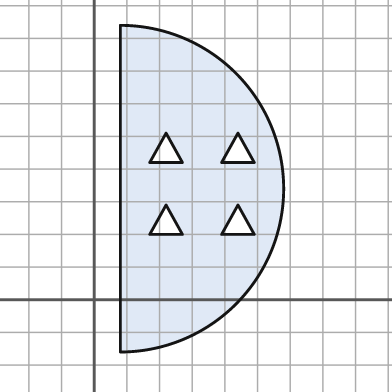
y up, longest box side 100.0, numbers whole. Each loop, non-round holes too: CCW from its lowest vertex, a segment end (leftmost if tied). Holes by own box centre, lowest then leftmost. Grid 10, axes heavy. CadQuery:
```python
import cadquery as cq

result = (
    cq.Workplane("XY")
    .moveTo(8.0, -16.0)
    .threePointArc((58.0, 34.0), (8.0, 84.0))
    .close()
    .moveTo(17.0, 20.0)
    .lineTo(27.0, 20.0)
    .lineTo(22.0, 29.0)
    .close()
    .moveTo(39.0, 20.0)
    .lineTo(49.0, 20.0)
    .lineTo(44.0, 29.0)
    .close()
    .moveTo(17.0, 42.0)
    .lineTo(27.0, 42.0)
    .lineTo(22.0, 51.0)
    .close()
    .moveTo(39.0, 42.0)
    .lineTo(49.0, 42.0)
    .lineTo(44.0, 51.0)
    .close()
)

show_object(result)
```